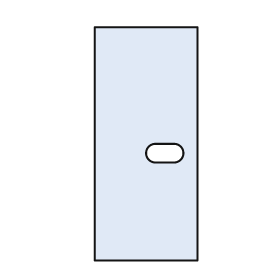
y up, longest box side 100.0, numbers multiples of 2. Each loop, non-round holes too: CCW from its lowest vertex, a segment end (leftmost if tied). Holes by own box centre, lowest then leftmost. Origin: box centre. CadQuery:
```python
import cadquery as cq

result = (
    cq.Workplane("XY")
    .moveTo(-22.0, -50.0)
    .lineTo(22.0, -50.0)
    .lineTo(22.0, 50.0)
    .lineTo(-22.0, 50.0)
    .close()
    .moveTo(4.0, -8.0)
    .lineTo(12.0, -8.0)
    .threePointArc((16.0, -4.0), (12.0, 0.0))
    .lineTo(4.0, 0.0)
    .threePointArc((0.0, -4.0), (4.0, -8.0))
    .close()
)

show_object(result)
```